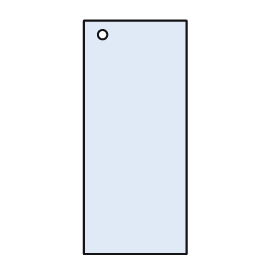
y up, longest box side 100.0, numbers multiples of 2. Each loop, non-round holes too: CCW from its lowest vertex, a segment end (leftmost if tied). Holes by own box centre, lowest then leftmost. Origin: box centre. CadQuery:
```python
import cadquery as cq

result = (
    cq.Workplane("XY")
    .moveTo(-22.0, -50.0)
    .lineTo(22.0, -50.0)
    .lineTo(22.0, 50.0)
    .lineTo(-22.0, 50.0)
    .close()
    .moveTo(-14.0, 44.0)
    .circle(2.0)
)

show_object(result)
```